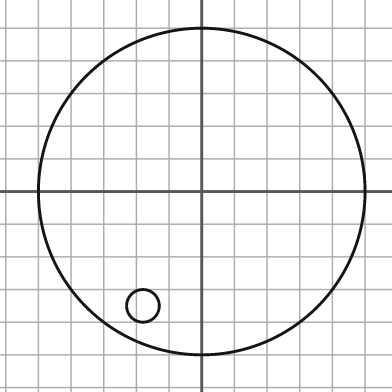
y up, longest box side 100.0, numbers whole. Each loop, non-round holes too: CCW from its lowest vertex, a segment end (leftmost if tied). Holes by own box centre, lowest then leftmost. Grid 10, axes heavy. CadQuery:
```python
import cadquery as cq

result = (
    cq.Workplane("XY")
    .moveTo(0.0, 0.0)
    .circle(50.0)
    .moveTo(-18.0, -35.0)
    .circle(5.0)
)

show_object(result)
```